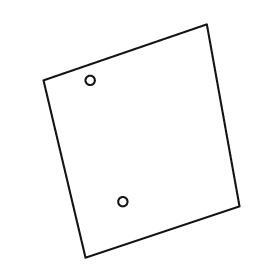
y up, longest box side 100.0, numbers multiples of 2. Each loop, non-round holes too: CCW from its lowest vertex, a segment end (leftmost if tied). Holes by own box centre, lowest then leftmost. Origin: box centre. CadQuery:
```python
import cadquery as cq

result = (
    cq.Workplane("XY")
    .moveTo(-24.0, -50.0)
    .lineTo(42.0, -28.0)
    .lineTo(28.0, 50.0)
    .lineTo(-42.0, 26.0)
    .close()
    .moveTo(-8.0, -26.0)
    .circle(2.0)
    .moveTo(-22.0, 26.0)
    .circle(2.0)
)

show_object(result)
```